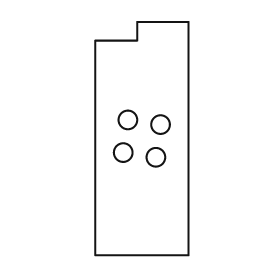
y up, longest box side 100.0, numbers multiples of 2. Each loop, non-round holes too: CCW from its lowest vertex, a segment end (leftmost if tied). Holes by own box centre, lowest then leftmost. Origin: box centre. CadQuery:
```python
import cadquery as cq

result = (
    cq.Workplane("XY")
    .moveTo(-20.0, -50.0)
    .lineTo(20.0, -50.0)
    .lineTo(20.0, 50.0)
    .lineTo(-2.0, 50.0)
    .lineTo(-2.0, 42.0)
    .lineTo(-20.0, 42.0)
    .close()
    .moveTo(6.0, -8.0)
    .circle(4.0)
    .moveTo(-8.0, -6.0)
    .circle(4.0)
    .moveTo(8.0, 6.0)
    .circle(4.0)
    .moveTo(-6.0, 8.0)
    .circle(4.0)
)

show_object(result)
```